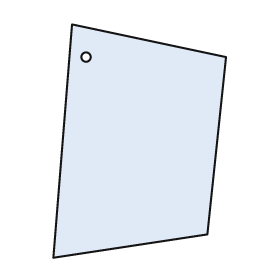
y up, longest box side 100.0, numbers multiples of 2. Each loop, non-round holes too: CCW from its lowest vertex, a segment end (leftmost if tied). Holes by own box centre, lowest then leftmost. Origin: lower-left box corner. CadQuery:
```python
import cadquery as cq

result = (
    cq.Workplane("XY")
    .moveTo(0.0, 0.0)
    .lineTo(66.0, 10.0)
    .lineTo(74.0, 86.0)
    .lineTo(8.0, 100.0)
    .close()
    .moveTo(14.0, 86.0)
    .circle(2.0)
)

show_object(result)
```